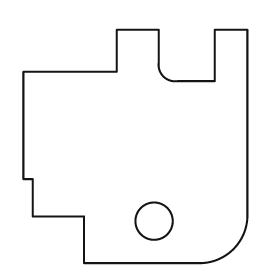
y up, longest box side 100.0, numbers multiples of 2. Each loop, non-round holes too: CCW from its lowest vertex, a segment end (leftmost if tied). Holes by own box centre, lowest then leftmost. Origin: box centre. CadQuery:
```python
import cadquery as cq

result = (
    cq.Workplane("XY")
    .moveTo(-22.0, -50.0)
    .lineTo(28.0, -50.0)
    .threePointArc((42.0, -44.0), (48.0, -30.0))
    .lineTo(48.0, 50.0)
    .lineTo(34.0, 50.0)
    .lineTo(34.0, 28.0)
    .lineTo(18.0, 28.0)
    .threePointArc((12.0, 30.0), (10.0, 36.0))
    .lineTo(10.0, 50.0)
    .lineTo(-8.0, 50.0)
    .lineTo(-8.0, 32.0)
    .lineTo(-48.0, 32.0)
    .lineTo(-48.0, -14.0)
    .lineTo(-44.0, -14.0)
    .lineTo(-44.0, -30.0)
    .lineTo(-22.0, -30.0)
    .close()
    .moveTo(8.0, -32.0)
    .circle(8.0)
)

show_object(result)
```